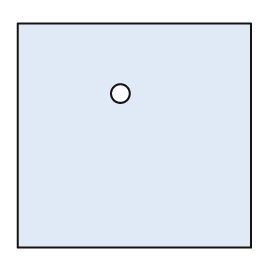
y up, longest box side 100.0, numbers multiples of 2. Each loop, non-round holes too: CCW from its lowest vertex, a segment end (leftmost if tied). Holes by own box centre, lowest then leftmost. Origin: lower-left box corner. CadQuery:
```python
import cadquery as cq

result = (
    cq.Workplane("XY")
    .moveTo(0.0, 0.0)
    .lineTo(100.0, 0.0)
    .lineTo(100.0, 96.0)
    .lineTo(0.0, 96.0)
    .close()
    .moveTo(44.0, 66.0)
    .circle(4.0)
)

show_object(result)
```